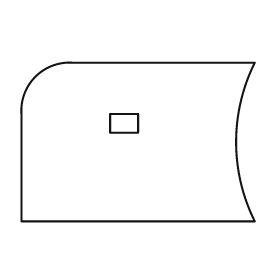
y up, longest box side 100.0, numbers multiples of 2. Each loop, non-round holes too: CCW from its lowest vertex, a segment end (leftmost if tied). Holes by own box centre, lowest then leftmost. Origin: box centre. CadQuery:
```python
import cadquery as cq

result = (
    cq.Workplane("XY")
    .moveTo(-50.0, -34.0)
    .lineTo(50.0, -34.0)
    .threePointArc((42.0, 0.0), (50.0, 34.0))
    .lineTo(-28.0, 34.0)
    .threePointArc((-44.0, 28.0), (-50.0, 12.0))
    .close()
    .moveTo(-12.0, 4.0)
    .lineTo(0.0, 4.0)
    .lineTo(0.0, 12.0)
    .lineTo(-12.0, 12.0)
    .close()
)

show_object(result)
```